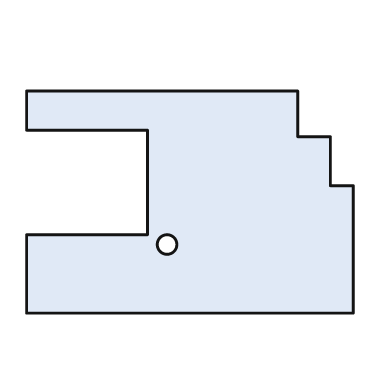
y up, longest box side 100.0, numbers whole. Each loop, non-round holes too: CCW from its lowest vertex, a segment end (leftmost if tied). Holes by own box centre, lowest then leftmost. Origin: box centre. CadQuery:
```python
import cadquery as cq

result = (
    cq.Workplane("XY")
    .moveTo(-50.0, -34.0)
    .lineTo(50.0, -34.0)
    .lineTo(50.0, 5.0)
    .lineTo(43.0, 5.0)
    .lineTo(43.0, 20.0)
    .lineTo(33.0, 20.0)
    .lineTo(33.0, 34.0)
    .lineTo(-50.0, 34.0)
    .lineTo(-50.0, 22.0)
    .lineTo(-13.0, 22.0)
    .lineTo(-13.0, -10.0)
    .lineTo(-50.0, -10.0)
    .close()
    .moveTo(-7.0, -13.0)
    .circle(3.0)
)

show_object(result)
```